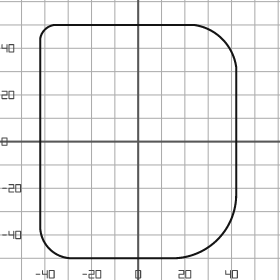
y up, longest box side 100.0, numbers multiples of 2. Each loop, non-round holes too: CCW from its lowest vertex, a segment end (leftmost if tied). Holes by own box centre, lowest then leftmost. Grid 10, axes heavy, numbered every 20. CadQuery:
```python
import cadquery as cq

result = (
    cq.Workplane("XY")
    .moveTo(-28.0, -50.0)
    .lineTo(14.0, -50.0)
    .threePointArc((34.0, -42.0), (42.0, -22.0))
    .lineTo(42.0, 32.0)
    .threePointArc((36.0, 44.0), (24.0, 50.0))
    .lineTo(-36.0, 50.0)
    .threePointArc((-40.0, 48.0), (-42.0, 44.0))
    .lineTo(-42.0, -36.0)
    .threePointArc((-38.0, -46.0), (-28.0, -50.0))
    .close()
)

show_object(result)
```